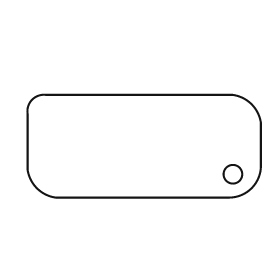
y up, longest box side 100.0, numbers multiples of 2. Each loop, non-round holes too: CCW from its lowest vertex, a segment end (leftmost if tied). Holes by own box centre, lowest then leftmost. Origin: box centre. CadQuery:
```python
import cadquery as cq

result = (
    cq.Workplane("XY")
    .moveTo(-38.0, -22.0)
    .lineTo(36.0, -22.0)
    .threePointArc((46.0, -18.0), (50.0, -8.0))
    .lineTo(50.0, 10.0)
    .threePointArc((46.0, 18.0), (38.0, 22.0))
    .lineTo(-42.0, 22.0)
    .threePointArc((-48.0, 20.0), (-50.0, 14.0))
    .lineTo(-50.0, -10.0)
    .threePointArc((-46.0, -18.0), (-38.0, -22.0))
    .close()
    .moveTo(38.0, -12.0)
    .circle(4.0)
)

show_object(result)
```